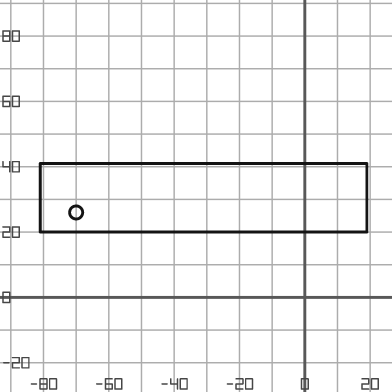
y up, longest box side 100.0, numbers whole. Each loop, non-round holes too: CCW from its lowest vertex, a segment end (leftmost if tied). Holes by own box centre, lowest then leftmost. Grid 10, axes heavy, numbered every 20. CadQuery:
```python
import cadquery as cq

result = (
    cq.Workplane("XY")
    .moveTo(-81.0, 20.0)
    .lineTo(19.0, 20.0)
    .lineTo(19.0, 41.0)
    .lineTo(-81.0, 41.0)
    .close()
    .moveTo(-70.0, 26.0)
    .circle(2.0)
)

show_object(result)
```